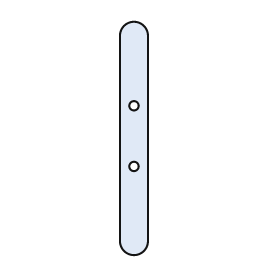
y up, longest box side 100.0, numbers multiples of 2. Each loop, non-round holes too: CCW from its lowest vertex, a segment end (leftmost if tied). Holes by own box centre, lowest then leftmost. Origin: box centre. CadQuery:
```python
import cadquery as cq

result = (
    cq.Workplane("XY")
    .moveTo(-6.0, -44.0)
    .threePointArc((0.0, -50.0), (6.0, -44.0))
    .lineTo(6.0, 44.0)
    .threePointArc((0.0, 50.0), (-6.0, 44.0))
    .close()
    .moveTo(0.0, -12.0)
    .circle(2.0)
    .moveTo(0.0, 14.0)
    .circle(2.0)
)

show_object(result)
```